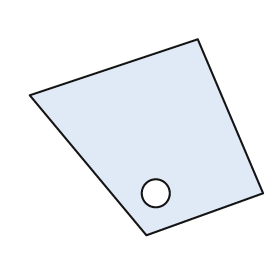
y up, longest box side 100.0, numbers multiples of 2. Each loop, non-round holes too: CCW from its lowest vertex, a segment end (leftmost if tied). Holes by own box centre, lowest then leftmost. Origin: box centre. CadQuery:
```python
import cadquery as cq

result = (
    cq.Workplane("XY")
    .moveTo(0.0, -42.0)
    .lineTo(50.0, -24.0)
    .lineTo(22.0, 42.0)
    .lineTo(-50.0, 18.0)
    .close()
    .moveTo(4.0, -24.0)
    .circle(6.0)
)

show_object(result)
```